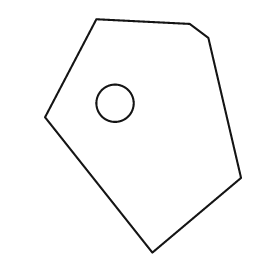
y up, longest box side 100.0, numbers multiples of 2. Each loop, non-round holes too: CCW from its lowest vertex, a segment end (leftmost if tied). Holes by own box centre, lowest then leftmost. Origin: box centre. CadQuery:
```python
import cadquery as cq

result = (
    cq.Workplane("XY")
    .moveTo(4.0, -50.0)
    .lineTo(42.0, -18.0)
    .lineTo(28.0, 42.0)
    .lineTo(20.0, 48.0)
    .lineTo(-20.0, 50.0)
    .lineTo(-42.0, 8.0)
    .close()
    .moveTo(-12.0, 14.0)
    .circle(8.0)
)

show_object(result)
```